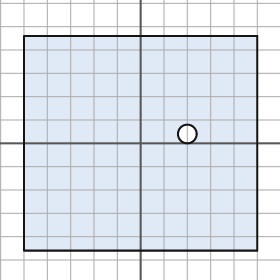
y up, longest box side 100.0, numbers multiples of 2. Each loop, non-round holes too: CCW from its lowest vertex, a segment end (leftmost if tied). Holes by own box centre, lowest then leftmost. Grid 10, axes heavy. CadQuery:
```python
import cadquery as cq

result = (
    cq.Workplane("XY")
    .moveTo(-50.0, -46.0)
    .lineTo(50.0, -46.0)
    .lineTo(50.0, 46.0)
    .lineTo(-50.0, 46.0)
    .close()
    .moveTo(20.0, 4.0)
    .circle(4.0)
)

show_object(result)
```